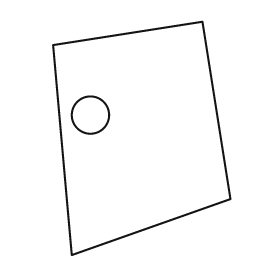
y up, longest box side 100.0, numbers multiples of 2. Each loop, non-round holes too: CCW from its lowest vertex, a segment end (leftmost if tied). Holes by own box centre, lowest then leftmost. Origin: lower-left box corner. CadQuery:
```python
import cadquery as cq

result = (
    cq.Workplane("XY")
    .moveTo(8.0, 0.0)
    .lineTo(76.0, 24.0)
    .lineTo(64.0, 100.0)
    .lineTo(0.0, 90.0)
    .close()
    .moveTo(16.0, 60.0)
    .circle(8.0)
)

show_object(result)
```